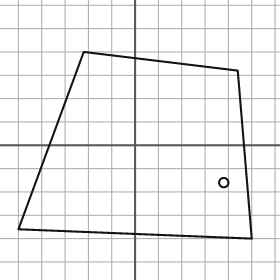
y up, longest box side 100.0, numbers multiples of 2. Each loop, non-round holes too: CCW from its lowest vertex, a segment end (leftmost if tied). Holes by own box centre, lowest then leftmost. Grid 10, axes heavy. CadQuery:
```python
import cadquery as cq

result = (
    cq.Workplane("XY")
    .moveTo(50.0, -40.0)
    .lineTo(44.0, 32.0)
    .lineTo(-22.0, 40.0)
    .lineTo(-50.0, -36.0)
    .close()
    .moveTo(38.0, -16.0)
    .circle(2.0)
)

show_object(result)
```